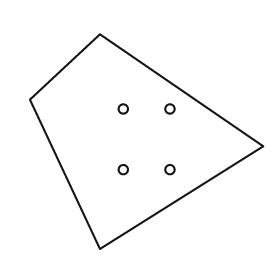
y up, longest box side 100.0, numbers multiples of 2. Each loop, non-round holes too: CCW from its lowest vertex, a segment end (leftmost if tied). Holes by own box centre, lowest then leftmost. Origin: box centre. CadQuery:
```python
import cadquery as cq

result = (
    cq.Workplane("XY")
    .moveTo(-20.0, -46.0)
    .lineTo(50.0, -2.0)
    .lineTo(-20.0, 46.0)
    .lineTo(-50.0, 18.0)
    .close()
    .moveTo(-10.0, -12.0)
    .circle(2.0)
    .moveTo(10.0, -12.0)
    .circle(2.0)
    .moveTo(-10.0, 14.0)
    .circle(2.0)
    .moveTo(10.0, 14.0)
    .circle(2.0)
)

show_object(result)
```